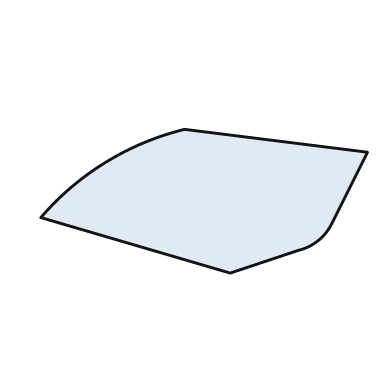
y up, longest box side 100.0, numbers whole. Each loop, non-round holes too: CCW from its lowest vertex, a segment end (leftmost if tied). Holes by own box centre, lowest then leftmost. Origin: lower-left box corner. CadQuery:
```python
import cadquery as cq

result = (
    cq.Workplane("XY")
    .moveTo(58.0, 0.0)
    .lineTo(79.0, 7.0)
    .threePointArc((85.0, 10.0), (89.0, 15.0))
    .lineTo(100.0, 37.0)
    .lineTo(44.0, 44.0)
    .threePointArc((20.0, 34.0), (0.0, 17.0))
    .close()
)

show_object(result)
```